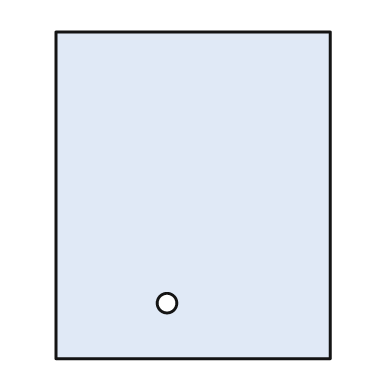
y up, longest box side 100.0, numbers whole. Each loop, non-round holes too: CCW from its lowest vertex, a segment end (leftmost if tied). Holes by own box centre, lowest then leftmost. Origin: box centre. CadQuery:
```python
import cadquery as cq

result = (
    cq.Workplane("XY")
    .moveTo(-42.0, -50.0)
    .lineTo(42.0, -50.0)
    .lineTo(42.0, 50.0)
    .lineTo(-42.0, 50.0)
    .close()
    .moveTo(-8.0, -33.0)
    .circle(3.0)
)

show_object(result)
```